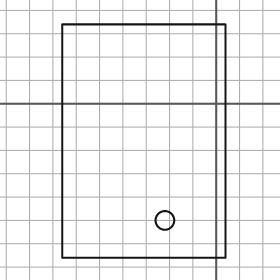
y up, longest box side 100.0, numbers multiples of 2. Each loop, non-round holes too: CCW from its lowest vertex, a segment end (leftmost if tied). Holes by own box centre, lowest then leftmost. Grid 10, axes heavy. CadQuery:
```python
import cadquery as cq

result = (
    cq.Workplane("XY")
    .moveTo(-66.0, -66.0)
    .lineTo(4.0, -66.0)
    .lineTo(4.0, 34.0)
    .lineTo(-66.0, 34.0)
    .close()
    .moveTo(-22.0, -50.0)
    .circle(4.0)
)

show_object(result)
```